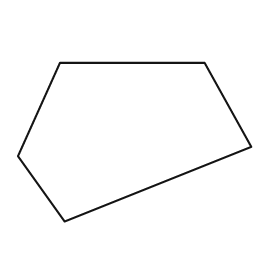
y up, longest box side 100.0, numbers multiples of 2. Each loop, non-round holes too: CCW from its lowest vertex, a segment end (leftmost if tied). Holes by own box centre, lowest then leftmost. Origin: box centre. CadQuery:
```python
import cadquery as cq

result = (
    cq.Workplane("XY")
    .moveTo(-30.0, -34.0)
    .lineTo(50.0, -2.0)
    .lineTo(30.0, 34.0)
    .lineTo(-32.0, 34.0)
    .lineTo(-50.0, -6.0)
    .close()
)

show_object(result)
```